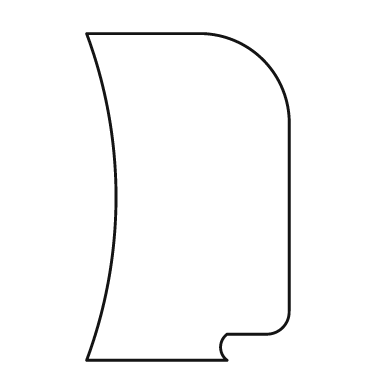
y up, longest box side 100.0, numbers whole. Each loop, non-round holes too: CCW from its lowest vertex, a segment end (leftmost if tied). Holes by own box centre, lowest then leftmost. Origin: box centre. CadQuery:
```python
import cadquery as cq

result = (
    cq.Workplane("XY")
    .moveTo(-31.0, -50.0)
    .lineTo(12.0, -50.0)
    .threePointArc((10.0, -46.0), (12.0, -42.0))
    .lineTo(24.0, -42.0)
    .threePointArc((29.0, -40.0), (31.0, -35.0))
    .lineTo(31.0, 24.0)
    .threePointArc((23.0, 42.0), (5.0, 50.0))
    .lineTo(-31.0, 50.0)
    .threePointArc((-22.0, 0.0), (-31.0, -50.0))
    .close()
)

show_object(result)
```